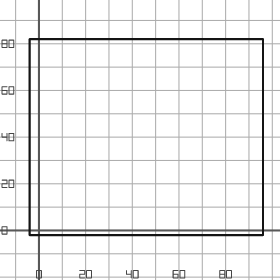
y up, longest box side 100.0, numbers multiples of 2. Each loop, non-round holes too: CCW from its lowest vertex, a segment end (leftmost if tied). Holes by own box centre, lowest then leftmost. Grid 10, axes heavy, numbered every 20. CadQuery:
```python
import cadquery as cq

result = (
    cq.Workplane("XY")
    .moveTo(-4.0, -2.0)
    .lineTo(96.0, -2.0)
    .lineTo(96.0, 82.0)
    .lineTo(-4.0, 82.0)
    .close()
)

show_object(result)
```